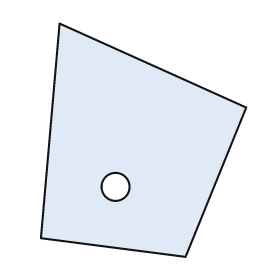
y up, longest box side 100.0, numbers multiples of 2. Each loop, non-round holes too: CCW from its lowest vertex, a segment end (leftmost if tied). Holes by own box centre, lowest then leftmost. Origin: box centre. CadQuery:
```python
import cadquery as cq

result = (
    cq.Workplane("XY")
    .moveTo(18.0, -50.0)
    .lineTo(44.0, 14.0)
    .lineTo(-36.0, 50.0)
    .lineTo(-44.0, -42.0)
    .close()
    .moveTo(-12.0, -20.0)
    .circle(6.0)
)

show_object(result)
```